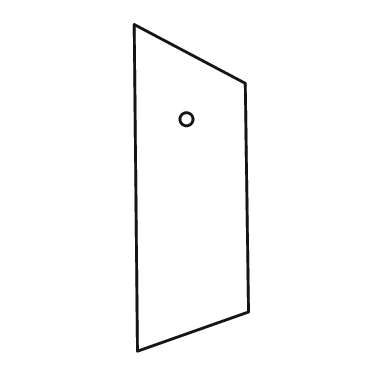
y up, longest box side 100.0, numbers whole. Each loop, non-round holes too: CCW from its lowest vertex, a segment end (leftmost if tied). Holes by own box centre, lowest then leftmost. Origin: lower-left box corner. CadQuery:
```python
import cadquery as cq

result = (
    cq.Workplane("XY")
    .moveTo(1.0, 0.0)
    .lineTo(35.0, 12.0)
    .lineTo(34.0, 82.0)
    .lineTo(0.0, 100.0)
    .close()
    .moveTo(16.0, 71.0)
    .circle(2.0)
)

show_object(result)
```